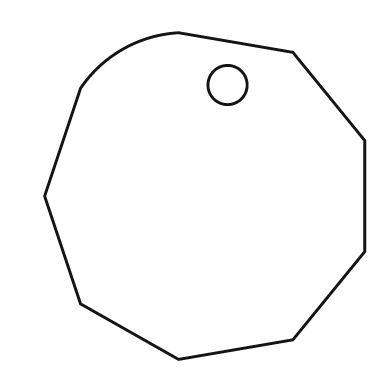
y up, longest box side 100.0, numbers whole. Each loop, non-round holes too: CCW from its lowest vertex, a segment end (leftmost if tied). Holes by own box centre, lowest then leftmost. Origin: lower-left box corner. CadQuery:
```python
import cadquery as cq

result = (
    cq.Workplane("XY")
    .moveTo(41.0, 0.0)
    .lineTo(76.0, 6.0)
    .lineTo(98.0, 33.0)
    .lineTo(98.0, 67.0)
    .lineTo(76.0, 94.0)
    .lineTo(41.0, 100.0)
    .threePointArc((24.0, 95.0), (11.0, 83.0))
    .lineTo(0.0, 50.0)
    .lineTo(11.0, 17.0)
    .close()
    .moveTo(56.0, 84.0)
    .circle(6.0)
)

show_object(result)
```